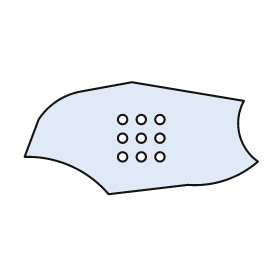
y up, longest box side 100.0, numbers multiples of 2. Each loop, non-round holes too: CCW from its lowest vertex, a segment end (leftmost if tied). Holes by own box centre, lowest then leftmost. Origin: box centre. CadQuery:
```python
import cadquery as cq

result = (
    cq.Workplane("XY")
    .moveTo(-14.0, -24.0)
    .lineTo(20.0, -20.0)
    .threePointArc((36.0, -18.0), (50.0, -10.0))
    .threePointArc((42.0, 2.0), (44.0, 16.0))
    .lineTo(-4.0, 24.0)
    .lineTo(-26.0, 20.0)
    .threePointArc((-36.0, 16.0), (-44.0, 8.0))
    .lineTo(-50.0, -8.0)
    .threePointArc((-30.0, -12.0), (-14.0, -24.0))
    .close()
    .moveTo(-8.0, -8.0)
    .circle(2.0)
    .moveTo(0.0, -8.0)
    .circle(2.0)
    .moveTo(8.0, -8.0)
    .circle(2.0)
    .moveTo(-8.0, 0.0)
    .circle(2.0)
    .moveTo(0.0, 0.0)
    .circle(2.0)
    .moveTo(8.0, 0.0)
    .circle(2.0)
    .moveTo(-8.0, 8.0)
    .circle(2.0)
    .moveTo(0.0, 8.0)
    .circle(2.0)
    .moveTo(8.0, 8.0)
    .circle(2.0)
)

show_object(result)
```